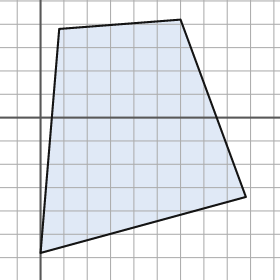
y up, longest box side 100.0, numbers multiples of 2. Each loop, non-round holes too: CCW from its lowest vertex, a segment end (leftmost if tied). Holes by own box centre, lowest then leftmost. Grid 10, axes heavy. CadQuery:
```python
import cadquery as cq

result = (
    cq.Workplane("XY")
    .moveTo(0.0, -58.0)
    .lineTo(88.0, -34.0)
    .lineTo(60.0, 42.0)
    .lineTo(8.0, 38.0)
    .close()
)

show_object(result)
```